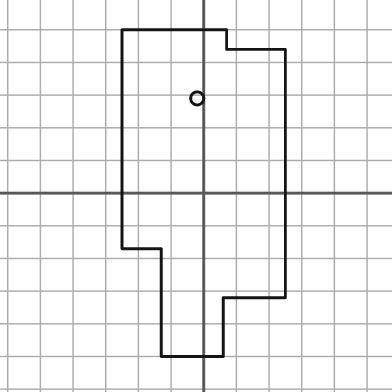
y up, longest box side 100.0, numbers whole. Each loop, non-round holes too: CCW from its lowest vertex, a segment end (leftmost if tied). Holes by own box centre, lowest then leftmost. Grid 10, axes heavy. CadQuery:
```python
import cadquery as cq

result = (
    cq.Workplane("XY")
    .moveTo(-13.0, -50.0)
    .lineTo(6.0, -50.0)
    .lineTo(6.0, -32.0)
    .lineTo(25.0, -32.0)
    .lineTo(25.0, 44.0)
    .lineTo(7.0, 44.0)
    .lineTo(7.0, 50.0)
    .lineTo(-25.0, 50.0)
    .lineTo(-25.0, -17.0)
    .lineTo(-13.0, -17.0)
    .close()
    .moveTo(-2.0, 29.0)
    .circle(2.0)
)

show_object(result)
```